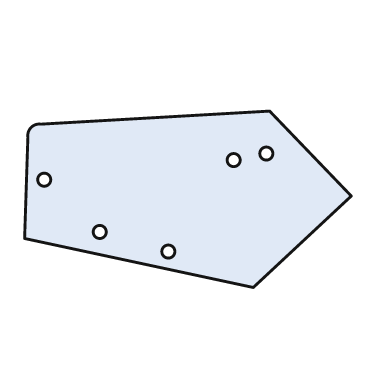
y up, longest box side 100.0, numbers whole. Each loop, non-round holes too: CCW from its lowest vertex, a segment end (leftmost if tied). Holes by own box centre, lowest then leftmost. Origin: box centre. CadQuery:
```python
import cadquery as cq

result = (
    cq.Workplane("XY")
    .moveTo(20.0, -27.0)
    .lineTo(50.0, 1.0)
    .lineTo(25.0, 27.0)
    .lineTo(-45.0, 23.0)
    .threePointArc((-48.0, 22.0), (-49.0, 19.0))
    .lineTo(-50.0, -12.0)
    .close()
    .moveTo(-6.0, -16.0)
    .circle(2.0)
    .moveTo(-27.0, -10.0)
    .circle(2.0)
    .moveTo(-44.0, 6.0)
    .circle(2.0)
    .moveTo(14.0, 12.0)
    .circle(2.0)
    .moveTo(24.0, 14.0)
    .circle(2.0)
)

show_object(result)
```